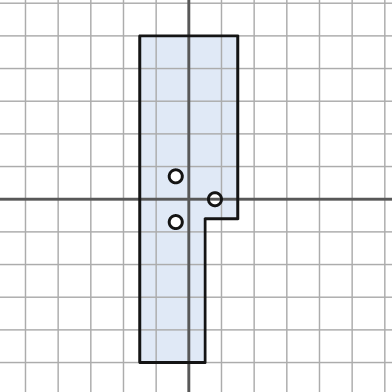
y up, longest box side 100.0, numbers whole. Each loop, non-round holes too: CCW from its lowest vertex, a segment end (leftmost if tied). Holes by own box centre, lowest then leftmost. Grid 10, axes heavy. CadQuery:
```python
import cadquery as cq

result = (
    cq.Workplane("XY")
    .moveTo(-15.0, -50.0)
    .lineTo(5.0, -50.0)
    .lineTo(5.0, -6.0)
    .lineTo(15.0, -6.0)
    .lineTo(15.0, 50.0)
    .lineTo(-15.0, 50.0)
    .close()
    .moveTo(-4.0, -7.0)
    .circle(2.0)
    .moveTo(8.0, 0.0)
    .circle(2.0)
    .moveTo(-4.0, 7.0)
    .circle(2.0)
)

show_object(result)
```